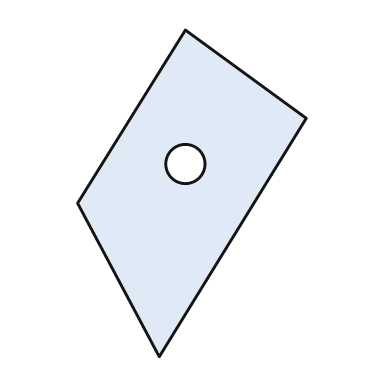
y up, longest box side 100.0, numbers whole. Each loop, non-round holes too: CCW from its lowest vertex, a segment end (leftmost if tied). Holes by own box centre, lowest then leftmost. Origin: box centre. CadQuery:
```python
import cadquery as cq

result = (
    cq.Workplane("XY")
    .moveTo(-10.0, -50.0)
    .lineTo(35.0, 23.0)
    .lineTo(-2.0, 50.0)
    .lineTo(-35.0, -3.0)
    .close()
    .moveTo(-2.0, 9.0)
    .circle(6.0)
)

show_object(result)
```